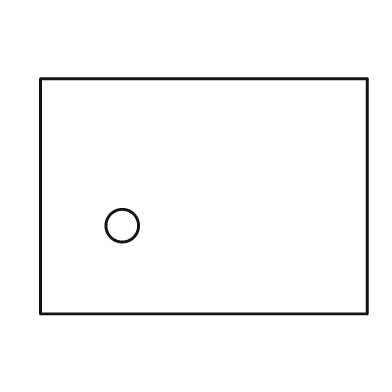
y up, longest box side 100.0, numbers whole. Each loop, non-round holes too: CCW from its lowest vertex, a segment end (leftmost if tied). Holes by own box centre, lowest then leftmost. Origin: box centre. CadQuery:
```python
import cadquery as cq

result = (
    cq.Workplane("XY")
    .moveTo(-50.0, -36.0)
    .lineTo(50.0, -36.0)
    .lineTo(50.0, 36.0)
    .lineTo(-50.0, 36.0)
    .close()
    .moveTo(-25.0, -9.0)
    .circle(5.0)
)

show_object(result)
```